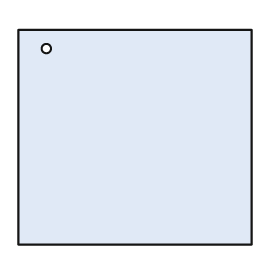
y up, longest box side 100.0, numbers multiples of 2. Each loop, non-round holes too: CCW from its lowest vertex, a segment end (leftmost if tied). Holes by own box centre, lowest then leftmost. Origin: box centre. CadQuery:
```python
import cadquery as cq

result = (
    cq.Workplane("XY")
    .moveTo(-50.0, -46.0)
    .lineTo(50.0, -46.0)
    .lineTo(50.0, 46.0)
    .lineTo(-50.0, 46.0)
    .close()
    .moveTo(-38.0, 38.0)
    .circle(2.0)
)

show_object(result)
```